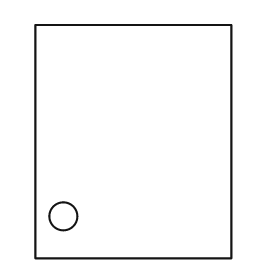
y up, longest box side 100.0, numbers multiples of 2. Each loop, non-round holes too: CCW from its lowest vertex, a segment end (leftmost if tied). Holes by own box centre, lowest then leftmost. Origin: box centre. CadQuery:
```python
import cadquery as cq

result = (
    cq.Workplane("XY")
    .moveTo(-42.0, -50.0)
    .lineTo(42.0, -50.0)
    .lineTo(42.0, 50.0)
    .lineTo(-42.0, 50.0)
    .close()
    .moveTo(-30.0, -32.0)
    .circle(6.0)
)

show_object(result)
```